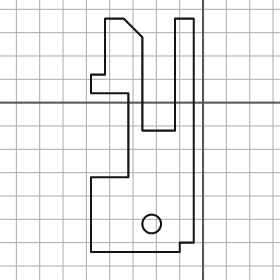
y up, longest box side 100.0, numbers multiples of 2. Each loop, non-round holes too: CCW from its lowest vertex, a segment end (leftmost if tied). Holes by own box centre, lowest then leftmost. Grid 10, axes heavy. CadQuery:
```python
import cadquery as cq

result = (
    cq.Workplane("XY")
    .moveTo(-48.0, -64.0)
    .lineTo(-10.0, -64.0)
    .lineTo(-10.0, -60.0)
    .lineTo(-4.0, -60.0)
    .lineTo(-4.0, 36.0)
    .lineTo(-12.0, 36.0)
    .lineTo(-12.0, -12.0)
    .lineTo(-26.0, -12.0)
    .lineTo(-26.0, 28.0)
    .lineTo(-34.0, 36.0)
    .lineTo(-42.0, 36.0)
    .lineTo(-42.0, 12.0)
    .lineTo(-48.0, 12.0)
    .lineTo(-48.0, 4.0)
    .lineTo(-32.0, 4.0)
    .lineTo(-32.0, -32.0)
    .lineTo(-48.0, -32.0)
    .close()
    .moveTo(-22.0, -52.0)
    .circle(4.0)
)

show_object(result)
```